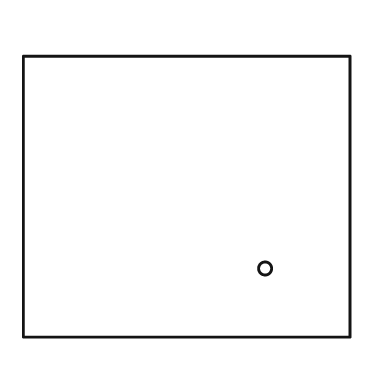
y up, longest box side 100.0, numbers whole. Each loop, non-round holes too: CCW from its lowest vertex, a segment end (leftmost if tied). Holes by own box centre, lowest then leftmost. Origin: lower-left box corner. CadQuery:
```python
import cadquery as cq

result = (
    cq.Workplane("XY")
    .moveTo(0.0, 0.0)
    .lineTo(100.0, 0.0)
    .lineTo(100.0, 86.0)
    .lineTo(0.0, 86.0)
    .close()
    .moveTo(74.0, 21.0)
    .circle(2.0)
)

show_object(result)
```